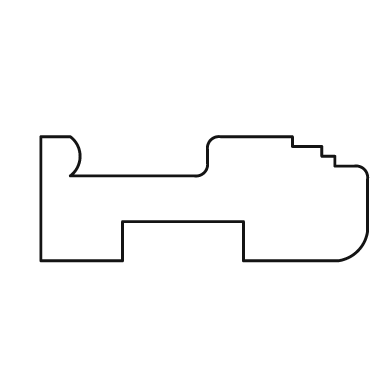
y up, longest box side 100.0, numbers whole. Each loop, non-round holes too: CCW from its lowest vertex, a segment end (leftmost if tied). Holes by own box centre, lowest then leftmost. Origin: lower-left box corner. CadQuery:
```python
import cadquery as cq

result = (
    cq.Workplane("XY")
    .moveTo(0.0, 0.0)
    .lineTo(25.0, 0.0)
    .lineTo(25.0, 12.0)
    .lineTo(62.0, 12.0)
    .lineTo(62.0, 0.0)
    .lineTo(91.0, 0.0)
    .threePointArc((97.0, 3.0), (100.0, 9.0))
    .lineTo(100.0, 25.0)
    .threePointArc((99.0, 28.0), (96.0, 29.0))
    .lineTo(90.0, 29.0)
    .lineTo(90.0, 32.0)
    .lineTo(86.0, 32.0)
    .lineTo(86.0, 35.0)
    .lineTo(77.0, 35.0)
    .lineTo(77.0, 38.0)
    .lineTo(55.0, 38.0)
    .threePointArc((52.0, 37.0), (51.0, 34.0))
    .lineTo(51.0, 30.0)
    .threePointArc((50.0, 27.0), (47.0, 26.0))
    .lineTo(9.0, 26.0)
    .threePointArc((12.0, 32.0), (9.0, 38.0))
    .lineTo(0.0, 38.0)
    .close()
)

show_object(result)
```